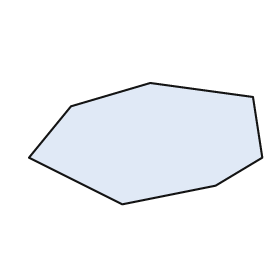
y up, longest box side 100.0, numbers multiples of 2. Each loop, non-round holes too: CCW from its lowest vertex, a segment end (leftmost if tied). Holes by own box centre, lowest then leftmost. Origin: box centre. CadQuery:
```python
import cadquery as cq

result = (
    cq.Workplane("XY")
    .moveTo(-10.0, -26.0)
    .lineTo(30.0, -18.0)
    .lineTo(50.0, -6.0)
    .lineTo(46.0, 20.0)
    .lineTo(2.0, 26.0)
    .lineTo(-32.0, 16.0)
    .lineTo(-50.0, -6.0)
    .close()
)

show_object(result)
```